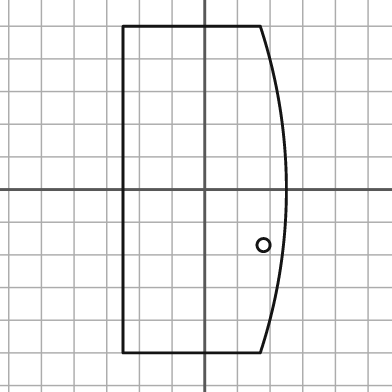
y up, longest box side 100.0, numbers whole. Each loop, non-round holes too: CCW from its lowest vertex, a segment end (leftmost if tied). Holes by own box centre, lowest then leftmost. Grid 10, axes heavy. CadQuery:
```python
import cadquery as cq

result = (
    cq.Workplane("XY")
    .moveTo(-25.0, -50.0)
    .lineTo(17.0, -50.0)
    .threePointArc((25.0, 0.0), (17.0, 50.0))
    .lineTo(-25.0, 50.0)
    .close()
    .moveTo(18.0, -17.0)
    .circle(2.0)
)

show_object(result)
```